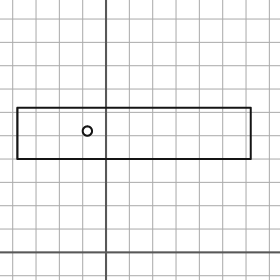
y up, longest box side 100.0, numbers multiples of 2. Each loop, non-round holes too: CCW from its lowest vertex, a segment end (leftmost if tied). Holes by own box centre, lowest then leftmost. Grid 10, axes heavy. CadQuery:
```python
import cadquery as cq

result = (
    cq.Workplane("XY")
    .moveTo(-38.0, 40.0)
    .lineTo(62.0, 40.0)
    .lineTo(62.0, 62.0)
    .lineTo(-38.0, 62.0)
    .close()
    .moveTo(-8.0, 52.0)
    .circle(2.0)
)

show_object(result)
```